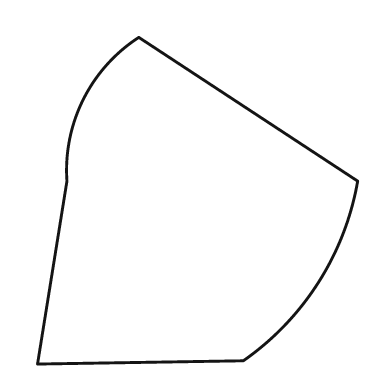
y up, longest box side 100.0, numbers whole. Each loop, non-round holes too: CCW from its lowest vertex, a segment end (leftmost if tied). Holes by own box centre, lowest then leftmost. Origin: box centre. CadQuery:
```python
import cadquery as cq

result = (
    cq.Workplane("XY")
    .moveTo(-49.0, -50.0)
    .lineTo(14.0, -49.0)
    .threePointArc((37.0, -25.0), (49.0, 6.0))
    .lineTo(-18.0, 50.0)
    .threePointArc((-35.0, 31.0), (-40.0, 6.0))
    .close()
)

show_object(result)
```